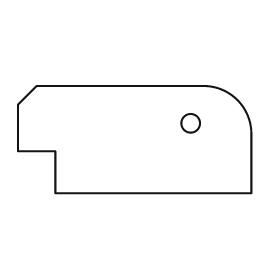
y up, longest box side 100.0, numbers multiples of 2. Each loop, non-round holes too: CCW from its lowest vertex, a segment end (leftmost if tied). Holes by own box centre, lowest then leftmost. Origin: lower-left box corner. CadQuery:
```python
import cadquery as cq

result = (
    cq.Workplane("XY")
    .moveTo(16.0, 0.0)
    .lineTo(100.0, 0.0)
    .lineTo(100.0, 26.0)
    .threePointArc((94.0, 40.0), (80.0, 46.0))
    .lineTo(8.0, 46.0)
    .lineTo(0.0, 38.0)
    .lineTo(0.0, 18.0)
    .lineTo(16.0, 18.0)
    .close()
    .moveTo(74.0, 30.0)
    .circle(4.0)
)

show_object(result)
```